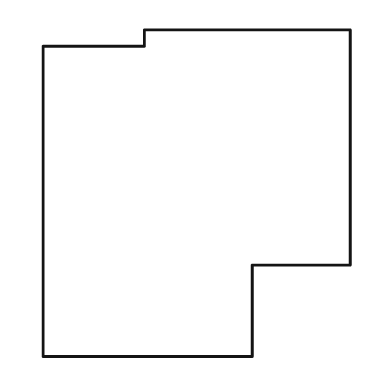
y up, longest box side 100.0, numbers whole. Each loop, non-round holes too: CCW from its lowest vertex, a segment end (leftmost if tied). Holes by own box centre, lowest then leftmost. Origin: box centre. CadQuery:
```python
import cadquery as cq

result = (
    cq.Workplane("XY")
    .moveTo(-47.0, -50.0)
    .lineTo(17.0, -50.0)
    .lineTo(17.0, -22.0)
    .lineTo(47.0, -22.0)
    .lineTo(47.0, 50.0)
    .lineTo(-16.0, 50.0)
    .lineTo(-16.0, 45.0)
    .lineTo(-47.0, 45.0)
    .close()
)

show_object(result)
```